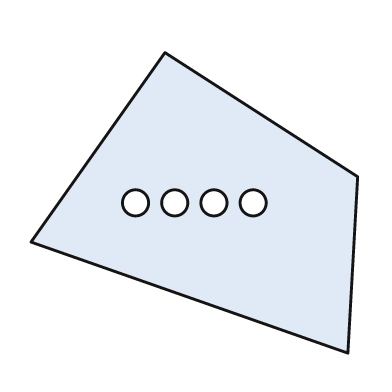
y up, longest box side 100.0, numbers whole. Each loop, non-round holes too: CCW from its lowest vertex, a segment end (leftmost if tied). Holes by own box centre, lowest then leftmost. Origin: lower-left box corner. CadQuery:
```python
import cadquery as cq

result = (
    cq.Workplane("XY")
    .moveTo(97.0, 0.0)
    .lineTo(100.0, 54.0)
    .lineTo(41.0, 92.0)
    .lineTo(0.0, 34.0)
    .close()
    .moveTo(32.0, 46.0)
    .circle(4.0)
    .moveTo(44.0, 46.0)
    .circle(4.0)
    .moveTo(56.0, 46.0)
    .circle(4.0)
    .moveTo(68.0, 46.0)
    .circle(4.0)
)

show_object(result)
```